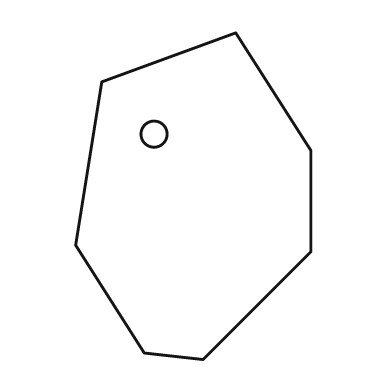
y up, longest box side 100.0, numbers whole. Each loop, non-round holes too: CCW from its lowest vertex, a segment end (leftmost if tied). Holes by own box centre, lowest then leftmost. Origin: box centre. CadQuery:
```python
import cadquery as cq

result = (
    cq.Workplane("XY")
    .moveTo(3.0, -50.0)
    .lineTo(36.0, -17.0)
    .lineTo(36.0, 14.0)
    .lineTo(13.0, 50.0)
    .lineTo(-28.0, 35.0)
    .lineTo(-36.0, -15.0)
    .lineTo(-15.0, -48.0)
    .close()
    .moveTo(-12.0, 19.0)
    .circle(4.0)
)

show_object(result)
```